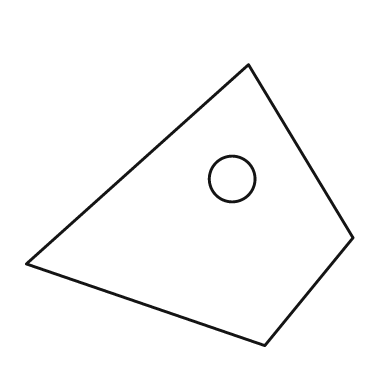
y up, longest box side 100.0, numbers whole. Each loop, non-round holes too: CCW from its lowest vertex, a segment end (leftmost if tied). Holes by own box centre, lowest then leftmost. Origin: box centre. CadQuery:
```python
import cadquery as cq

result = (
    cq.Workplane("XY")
    .moveTo(23.0, -43.0)
    .lineTo(50.0, -10.0)
    .lineTo(18.0, 43.0)
    .lineTo(-50.0, -18.0)
    .close()
    .moveTo(13.0, 8.0)
    .circle(7.0)
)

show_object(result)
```